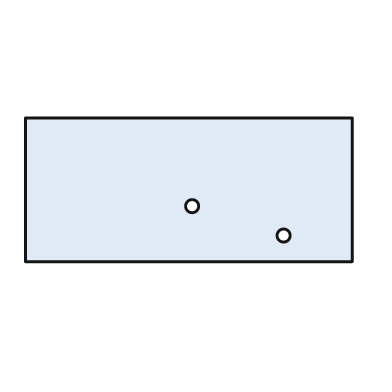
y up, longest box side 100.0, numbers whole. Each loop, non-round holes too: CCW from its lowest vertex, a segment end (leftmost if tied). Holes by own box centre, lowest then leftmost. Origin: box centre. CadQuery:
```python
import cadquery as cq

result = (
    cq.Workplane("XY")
    .moveTo(-50.0, -22.0)
    .lineTo(50.0, -22.0)
    .lineTo(50.0, 22.0)
    .lineTo(-50.0, 22.0)
    .close()
    .moveTo(29.0, -14.0)
    .circle(2.0)
    .moveTo(1.0, -5.0)
    .circle(2.0)
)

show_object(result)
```